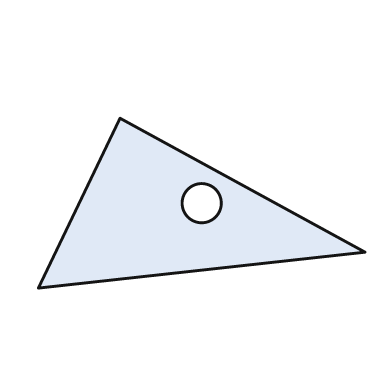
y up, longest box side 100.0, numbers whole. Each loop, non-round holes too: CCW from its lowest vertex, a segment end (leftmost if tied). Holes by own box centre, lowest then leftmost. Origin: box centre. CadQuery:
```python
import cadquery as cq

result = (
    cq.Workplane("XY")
    .moveTo(-50.0, -26.0)
    .lineTo(50.0, -15.0)
    .lineTo(-25.0, 26.0)
    .close()
    .moveTo(0.0, 0.0)
    .circle(6.0)
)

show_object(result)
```